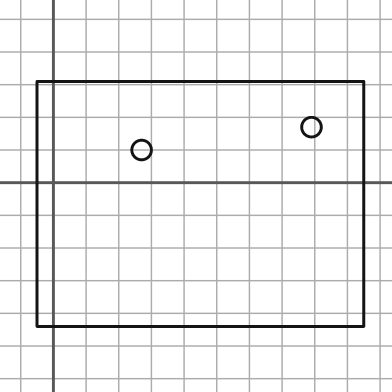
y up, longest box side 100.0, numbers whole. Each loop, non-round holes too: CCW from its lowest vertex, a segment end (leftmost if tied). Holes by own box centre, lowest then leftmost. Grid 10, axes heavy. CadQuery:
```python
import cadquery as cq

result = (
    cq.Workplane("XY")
    .moveTo(-5.0, -44.0)
    .lineTo(95.0, -44.0)
    .lineTo(95.0, 31.0)
    .lineTo(-5.0, 31.0)
    .close()
    .moveTo(27.0, 10.0)
    .circle(3.0)
    .moveTo(79.0, 17.0)
    .circle(3.0)
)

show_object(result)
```